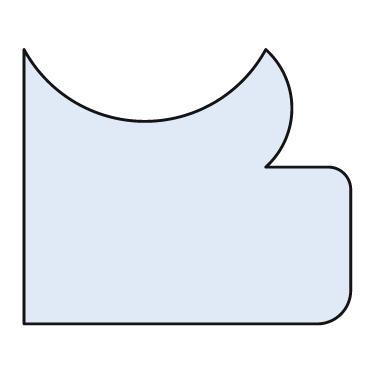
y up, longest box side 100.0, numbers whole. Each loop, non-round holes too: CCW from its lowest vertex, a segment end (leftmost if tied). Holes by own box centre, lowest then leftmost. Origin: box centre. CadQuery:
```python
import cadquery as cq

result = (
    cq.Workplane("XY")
    .moveTo(-50.0, -42.0)
    .lineTo(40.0, -42.0)
    .threePointArc((47.0, -39.0), (50.0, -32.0))
    .lineTo(50.0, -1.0)
    .threePointArc((48.0, 4.0), (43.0, 6.0))
    .lineTo(24.0, 6.0)
    .threePointArc((32.0, 24.0), (24.0, 42.0))
    .threePointArc((-13.0, 20.0), (-50.0, 42.0))
    .close()
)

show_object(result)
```